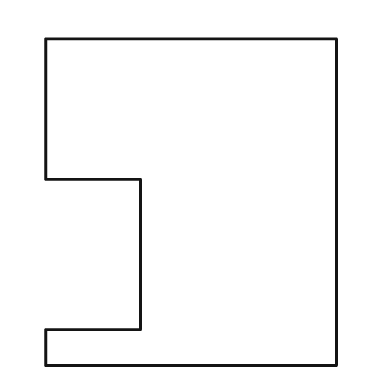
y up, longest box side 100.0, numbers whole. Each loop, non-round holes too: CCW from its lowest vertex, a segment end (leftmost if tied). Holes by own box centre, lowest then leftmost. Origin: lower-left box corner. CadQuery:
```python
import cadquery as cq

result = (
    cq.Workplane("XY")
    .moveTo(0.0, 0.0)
    .lineTo(89.0, 0.0)
    .lineTo(89.0, 100.0)
    .lineTo(0.0, 100.0)
    .lineTo(0.0, 57.0)
    .lineTo(29.0, 57.0)
    .lineTo(29.0, 11.0)
    .lineTo(0.0, 11.0)
    .close()
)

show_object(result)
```